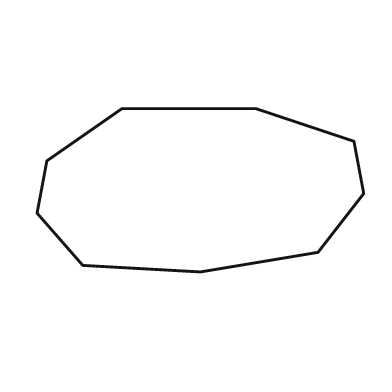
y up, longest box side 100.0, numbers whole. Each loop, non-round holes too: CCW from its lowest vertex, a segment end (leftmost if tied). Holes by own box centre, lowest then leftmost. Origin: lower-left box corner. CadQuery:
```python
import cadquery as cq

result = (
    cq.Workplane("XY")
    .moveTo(50.0, 0.0)
    .lineTo(86.0, 6.0)
    .lineTo(100.0, 24.0)
    .lineTo(97.0, 40.0)
    .lineTo(67.0, 50.0)
    .lineTo(26.0, 50.0)
    .lineTo(3.0, 34.0)
    .lineTo(0.0, 18.0)
    .lineTo(14.0, 2.0)
    .close()
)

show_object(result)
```